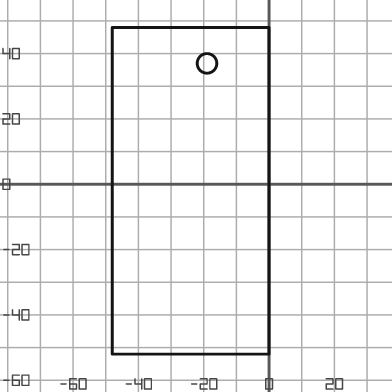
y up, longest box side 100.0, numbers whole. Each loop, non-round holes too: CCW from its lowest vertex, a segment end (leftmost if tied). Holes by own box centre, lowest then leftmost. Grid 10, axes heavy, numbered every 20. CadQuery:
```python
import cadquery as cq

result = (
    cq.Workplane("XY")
    .moveTo(-48.0, -52.0)
    .lineTo(0.0, -52.0)
    .lineTo(0.0, 48.0)
    .lineTo(-48.0, 48.0)
    .close()
    .moveTo(-19.0, 37.0)
    .circle(3.0)
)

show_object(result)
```